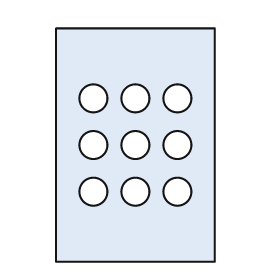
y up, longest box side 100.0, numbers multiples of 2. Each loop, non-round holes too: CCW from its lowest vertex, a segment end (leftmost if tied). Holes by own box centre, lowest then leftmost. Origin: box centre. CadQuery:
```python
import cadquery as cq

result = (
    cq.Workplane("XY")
    .moveTo(-34.0, -50.0)
    .lineTo(34.0, -50.0)
    .lineTo(34.0, 50.0)
    .lineTo(-34.0, 50.0)
    .close()
    .moveTo(-18.0, -20.0)
    .circle(6.0)
    .moveTo(0.0, -20.0)
    .circle(6.0)
    .moveTo(18.0, -20.0)
    .circle(6.0)
    .moveTo(-18.0, 0.0)
    .circle(6.0)
    .moveTo(0.0, 0.0)
    .circle(6.0)
    .moveTo(18.0, 0.0)
    .circle(6.0)
    .moveTo(-18.0, 20.0)
    .circle(6.0)
    .moveTo(0.0, 20.0)
    .circle(6.0)
    .moveTo(18.0, 20.0)
    .circle(6.0)
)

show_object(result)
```